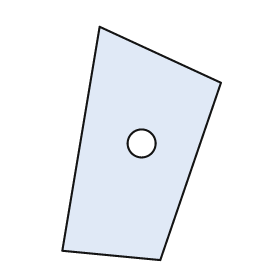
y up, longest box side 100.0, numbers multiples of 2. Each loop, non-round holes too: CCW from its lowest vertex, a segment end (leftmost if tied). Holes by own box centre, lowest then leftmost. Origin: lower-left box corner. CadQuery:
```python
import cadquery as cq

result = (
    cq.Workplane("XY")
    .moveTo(42.0, 0.0)
    .lineTo(68.0, 76.0)
    .lineTo(16.0, 100.0)
    .lineTo(0.0, 4.0)
    .close()
    .moveTo(34.0, 50.0)
    .circle(6.0)
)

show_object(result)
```